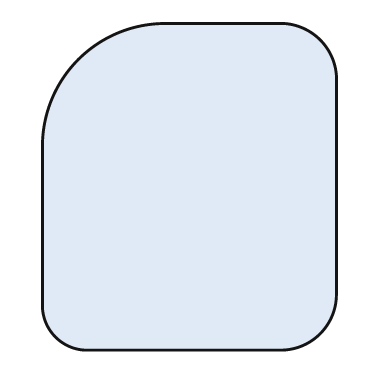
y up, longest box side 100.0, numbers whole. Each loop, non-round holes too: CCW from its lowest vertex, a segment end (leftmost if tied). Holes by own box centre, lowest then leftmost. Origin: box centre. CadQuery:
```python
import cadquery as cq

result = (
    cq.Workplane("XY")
    .moveTo(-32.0, -50.0)
    .lineTo(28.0, -50.0)
    .threePointArc((40.0, -45.0), (45.0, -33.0))
    .lineTo(45.0, 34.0)
    .threePointArc((40.0, 45.0), (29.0, 50.0))
    .lineTo(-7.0, 50.0)
    .threePointArc((-34.0, 39.0), (-45.0, 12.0))
    .lineTo(-45.0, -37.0)
    .threePointArc((-41.0, -46.0), (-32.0, -50.0))
    .close()
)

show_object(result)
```